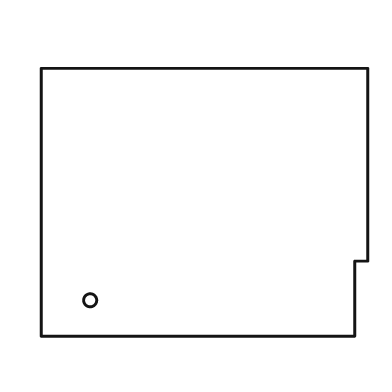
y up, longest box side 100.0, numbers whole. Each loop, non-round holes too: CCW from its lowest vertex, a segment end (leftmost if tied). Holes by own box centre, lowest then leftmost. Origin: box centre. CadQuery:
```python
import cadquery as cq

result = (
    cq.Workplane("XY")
    .moveTo(-50.0, -41.0)
    .lineTo(46.0, -41.0)
    .lineTo(46.0, -18.0)
    .lineTo(50.0, -18.0)
    .lineTo(50.0, 41.0)
    .lineTo(-50.0, 41.0)
    .close()
    .moveTo(-35.0, -30.0)
    .circle(2.0)
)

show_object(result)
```